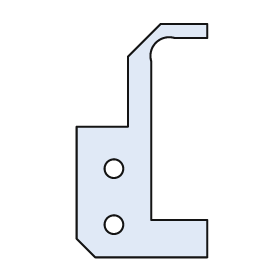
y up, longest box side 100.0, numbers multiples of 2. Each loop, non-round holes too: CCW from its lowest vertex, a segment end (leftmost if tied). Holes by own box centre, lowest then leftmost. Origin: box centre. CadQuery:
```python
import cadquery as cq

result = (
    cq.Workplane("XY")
    .moveTo(-20.0, -50.0)
    .lineTo(28.0, -50.0)
    .lineTo(28.0, -34.0)
    .lineTo(4.0, -34.0)
    .lineTo(4.0, 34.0)
    .threePointArc((6.0, 42.0), (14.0, 44.0))
    .lineTo(28.0, 44.0)
    .lineTo(28.0, 50.0)
    .lineTo(8.0, 50.0)
    .lineTo(-6.0, 36.0)
    .lineTo(-6.0, 6.0)
    .lineTo(-28.0, 6.0)
    .lineTo(-28.0, -42.0)
    .close()
    .moveTo(-12.0, -36.0)
    .circle(4.0)
    .moveTo(-12.0, -12.0)
    .circle(4.0)
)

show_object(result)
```